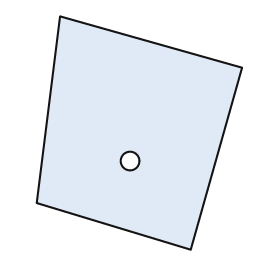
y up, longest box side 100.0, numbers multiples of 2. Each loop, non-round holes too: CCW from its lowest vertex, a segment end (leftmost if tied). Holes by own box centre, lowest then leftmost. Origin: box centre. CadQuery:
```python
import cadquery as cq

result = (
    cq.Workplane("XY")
    .moveTo(22.0, -50.0)
    .lineTo(44.0, 28.0)
    .lineTo(-34.0, 50.0)
    .lineTo(-44.0, -30.0)
    .close()
    .moveTo(-4.0, -12.0)
    .circle(4.0)
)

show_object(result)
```